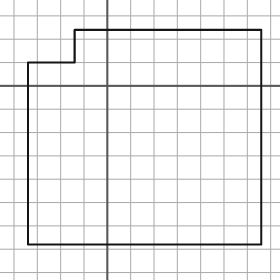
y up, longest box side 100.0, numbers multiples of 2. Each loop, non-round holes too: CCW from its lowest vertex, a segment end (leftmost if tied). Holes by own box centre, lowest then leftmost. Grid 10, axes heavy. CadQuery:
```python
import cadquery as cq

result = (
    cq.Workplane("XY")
    .moveTo(-34.0, -68.0)
    .lineTo(66.0, -68.0)
    .lineTo(66.0, 24.0)
    .lineTo(-14.0, 24.0)
    .lineTo(-14.0, 10.0)
    .lineTo(-34.0, 10.0)
    .close()
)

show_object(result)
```